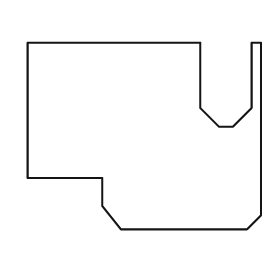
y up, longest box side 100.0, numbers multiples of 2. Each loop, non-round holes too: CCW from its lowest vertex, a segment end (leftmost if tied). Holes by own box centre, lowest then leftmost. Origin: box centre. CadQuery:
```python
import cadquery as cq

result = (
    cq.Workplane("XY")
    .moveTo(-10.0, -40.0)
    .lineTo(44.0, -40.0)
    .lineTo(50.0, -34.0)
    .lineTo(50.0, 40.0)
    .lineTo(46.0, 40.0)
    .lineTo(46.0, 12.0)
    .lineTo(38.0, 4.0)
    .lineTo(32.0, 4.0)
    .lineTo(24.0, 12.0)
    .lineTo(24.0, 40.0)
    .lineTo(-50.0, 40.0)
    .lineTo(-50.0, -18.0)
    .lineTo(-18.0, -18.0)
    .lineTo(-18.0, -30.0)
    .close()
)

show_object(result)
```